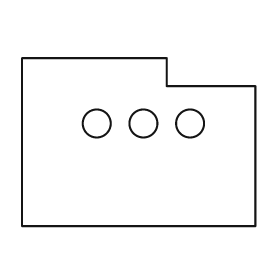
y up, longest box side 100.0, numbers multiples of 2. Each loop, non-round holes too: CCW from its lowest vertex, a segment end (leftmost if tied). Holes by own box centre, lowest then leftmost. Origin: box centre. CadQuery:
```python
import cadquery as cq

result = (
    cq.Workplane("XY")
    .moveTo(-50.0, -36.0)
    .lineTo(50.0, -36.0)
    .lineTo(50.0, 24.0)
    .lineTo(12.0, 24.0)
    .lineTo(12.0, 36.0)
    .lineTo(-50.0, 36.0)
    .close()
    .moveTo(-18.0, 8.0)
    .circle(6.0)
    .moveTo(2.0, 8.0)
    .circle(6.0)
    .moveTo(22.0, 8.0)
    .circle(6.0)
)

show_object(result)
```